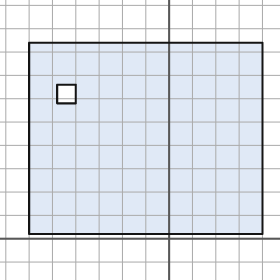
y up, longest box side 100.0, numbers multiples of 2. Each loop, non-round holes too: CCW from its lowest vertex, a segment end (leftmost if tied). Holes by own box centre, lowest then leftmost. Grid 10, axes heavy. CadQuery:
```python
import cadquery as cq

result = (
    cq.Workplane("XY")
    .moveTo(-60.0, 2.0)
    .lineTo(40.0, 2.0)
    .lineTo(40.0, 84.0)
    .lineTo(-60.0, 84.0)
    .close()
    .moveTo(-48.0, 58.0)
    .lineTo(-40.0, 58.0)
    .lineTo(-40.0, 66.0)
    .lineTo(-48.0, 66.0)
    .close()
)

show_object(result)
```